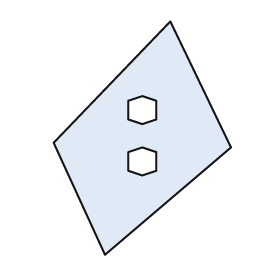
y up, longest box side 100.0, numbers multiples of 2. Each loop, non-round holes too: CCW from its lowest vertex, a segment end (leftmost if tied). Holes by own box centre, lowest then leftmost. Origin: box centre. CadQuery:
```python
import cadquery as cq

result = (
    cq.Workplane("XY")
    .moveTo(-16.0, -50.0)
    .lineTo(38.0, -4.0)
    .lineTo(12.0, 50.0)
    .lineTo(-38.0, -2.0)
    .close()
    .moveTo(0.0, -16.0)
    .lineTo(6.0, -14.0)
    .lineTo(6.0, -6.0)
    .lineTo(0.0, -4.0)
    .lineTo(-6.0, -6.0)
    .lineTo(-6.0, -14.0)
    .close()
    .moveTo(0.0, 6.0)
    .lineTo(6.0, 8.0)
    .lineTo(6.0, 16.0)
    .lineTo(0.0, 18.0)
    .lineTo(-6.0, 16.0)
    .lineTo(-6.0, 8.0)
    .close()
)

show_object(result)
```